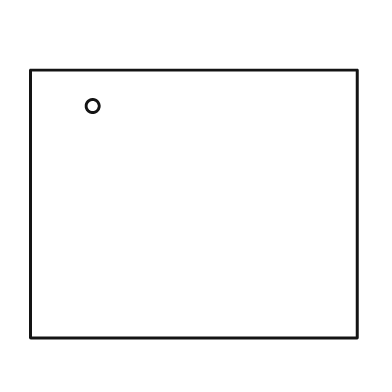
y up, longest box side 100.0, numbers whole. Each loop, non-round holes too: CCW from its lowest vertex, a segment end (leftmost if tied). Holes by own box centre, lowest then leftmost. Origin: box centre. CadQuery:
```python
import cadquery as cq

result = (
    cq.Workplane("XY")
    .moveTo(-50.0, -41.0)
    .lineTo(50.0, -41.0)
    .lineTo(50.0, 41.0)
    .lineTo(-50.0, 41.0)
    .close()
    .moveTo(-31.0, 30.0)
    .circle(2.0)
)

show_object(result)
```